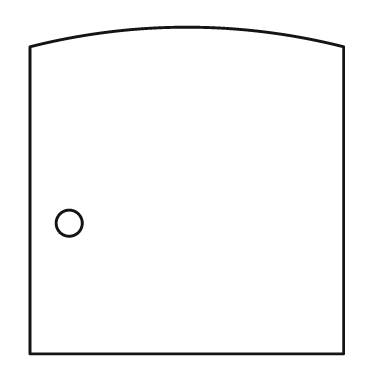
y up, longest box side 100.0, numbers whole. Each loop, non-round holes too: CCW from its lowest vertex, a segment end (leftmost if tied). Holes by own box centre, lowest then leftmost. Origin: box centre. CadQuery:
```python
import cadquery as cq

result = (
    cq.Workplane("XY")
    .moveTo(-48.0, -50.0)
    .lineTo(48.0, -50.0)
    .lineTo(48.0, 44.0)
    .threePointArc((0.0, 50.0), (-48.0, 44.0))
    .close()
    .moveTo(-36.0, -10.0)
    .circle(4.0)
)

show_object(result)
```